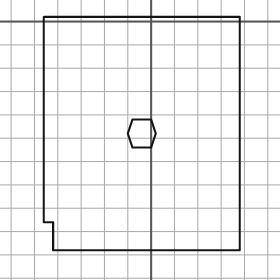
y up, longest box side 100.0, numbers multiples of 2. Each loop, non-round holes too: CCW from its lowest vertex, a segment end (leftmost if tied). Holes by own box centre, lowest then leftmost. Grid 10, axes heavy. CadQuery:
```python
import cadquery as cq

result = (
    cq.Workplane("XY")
    .moveTo(-42.0, -98.0)
    .lineTo(38.0, -98.0)
    .lineTo(38.0, 2.0)
    .lineTo(-46.0, 2.0)
    .lineTo(-46.0, -86.0)
    .lineTo(-42.0, -86.0)
    .close()
    .moveTo(-8.0, -54.0)
    .lineTo(0.0, -54.0)
    .lineTo(2.0, -48.0)
    .lineTo(0.0, -42.0)
    .lineTo(-8.0, -42.0)
    .lineTo(-10.0, -48.0)
    .close()
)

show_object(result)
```